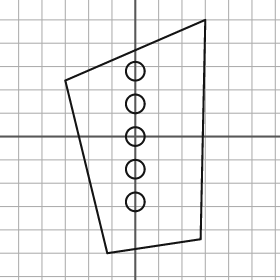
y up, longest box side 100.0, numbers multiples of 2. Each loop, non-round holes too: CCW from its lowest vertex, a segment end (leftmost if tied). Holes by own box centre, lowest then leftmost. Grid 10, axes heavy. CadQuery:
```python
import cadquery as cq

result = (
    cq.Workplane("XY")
    .moveTo(-12.0, -50.0)
    .lineTo(28.0, -44.0)
    .lineTo(30.0, 50.0)
    .lineTo(-30.0, 24.0)
    .close()
    .moveTo(0.0, -28.0)
    .circle(4.0)
    .moveTo(0.0, -14.0)
    .circle(4.0)
    .moveTo(0.0, 0.0)
    .circle(4.0)
    .moveTo(0.0, 14.0)
    .circle(4.0)
    .moveTo(0.0, 28.0)
    .circle(4.0)
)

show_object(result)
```